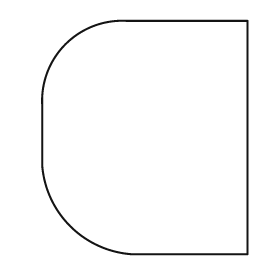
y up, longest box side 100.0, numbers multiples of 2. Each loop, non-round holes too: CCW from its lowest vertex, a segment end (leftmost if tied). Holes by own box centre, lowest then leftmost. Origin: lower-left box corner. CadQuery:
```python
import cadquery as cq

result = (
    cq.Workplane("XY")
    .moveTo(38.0, 0.0)
    .lineTo(88.0, 0.0)
    .lineTo(88.0, 100.0)
    .lineTo(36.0, 100.0)
    .threePointArc((10.0, 90.0), (0.0, 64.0))
    .lineTo(0.0, 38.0)
    .threePointArc((12.0, 12.0), (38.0, 0.0))
    .close()
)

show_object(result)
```